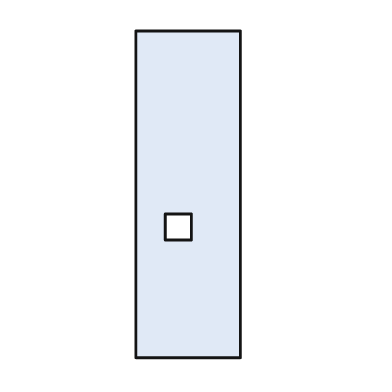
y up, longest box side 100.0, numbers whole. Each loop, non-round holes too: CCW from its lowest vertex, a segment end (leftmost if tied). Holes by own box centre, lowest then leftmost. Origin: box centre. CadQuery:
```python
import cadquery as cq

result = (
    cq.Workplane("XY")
    .moveTo(-16.0, -50.0)
    .lineTo(16.0, -50.0)
    .lineTo(16.0, 50.0)
    .lineTo(-16.0, 50.0)
    .close()
    .moveTo(-7.0, -14.0)
    .lineTo(1.0, -14.0)
    .lineTo(1.0, -6.0)
    .lineTo(-7.0, -6.0)
    .close()
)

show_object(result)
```